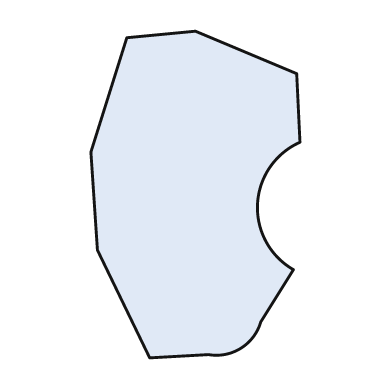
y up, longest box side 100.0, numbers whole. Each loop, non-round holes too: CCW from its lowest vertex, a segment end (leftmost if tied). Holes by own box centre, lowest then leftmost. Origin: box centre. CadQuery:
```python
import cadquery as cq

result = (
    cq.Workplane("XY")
    .moveTo(-14.0, -50.0)
    .lineTo(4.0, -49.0)
    .threePointArc((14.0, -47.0), (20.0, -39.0))
    .lineTo(30.0, -23.0)
    .threePointArc((19.0, -3.0), (32.0, 16.0))
    .lineTo(31.0, 37.0)
    .lineTo(0.0, 50.0)
    .lineTo(-21.0, 48.0)
    .lineTo(-32.0, 13.0)
    .lineTo(-30.0, -17.0)
    .close()
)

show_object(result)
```